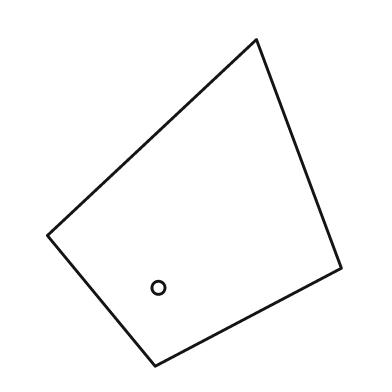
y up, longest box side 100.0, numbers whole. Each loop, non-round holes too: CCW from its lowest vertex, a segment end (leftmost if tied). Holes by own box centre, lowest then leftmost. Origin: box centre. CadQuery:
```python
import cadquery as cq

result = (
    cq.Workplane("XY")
    .moveTo(-12.0, -50.0)
    .lineTo(45.0, -20.0)
    .lineTo(19.0, 50.0)
    .lineTo(-45.0, -10.0)
    .close()
    .moveTo(-11.0, -26.0)
    .circle(2.0)
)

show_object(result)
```